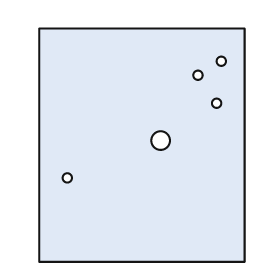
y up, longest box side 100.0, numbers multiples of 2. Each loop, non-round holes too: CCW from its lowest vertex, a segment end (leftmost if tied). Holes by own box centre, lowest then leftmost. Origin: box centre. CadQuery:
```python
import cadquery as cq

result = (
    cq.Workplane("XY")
    .moveTo(-44.0, -50.0)
    .lineTo(44.0, -50.0)
    .lineTo(44.0, 50.0)
    .lineTo(-44.0, 50.0)
    .close()
    .moveTo(-32.0, -14.0)
    .circle(2.0)
    .moveTo(8.0, 2.0)
    .circle(4.0)
    .moveTo(32.0, 18.0)
    .circle(2.0)
    .moveTo(24.0, 30.0)
    .circle(2.0)
    .moveTo(34.0, 36.0)
    .circle(2.0)
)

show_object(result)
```